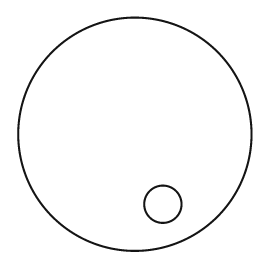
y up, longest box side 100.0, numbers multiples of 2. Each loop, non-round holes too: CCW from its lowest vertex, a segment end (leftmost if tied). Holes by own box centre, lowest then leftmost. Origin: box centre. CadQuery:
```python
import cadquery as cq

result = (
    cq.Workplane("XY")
    .moveTo(0.0, 0.0)
    .circle(50.0)
    .moveTo(12.0, -30.0)
    .circle(8.0)
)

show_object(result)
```